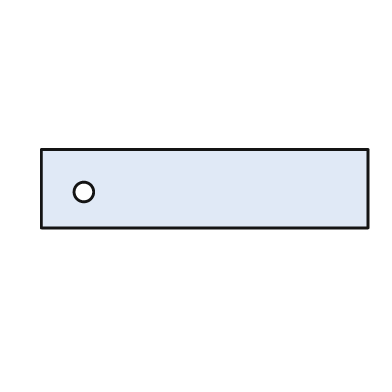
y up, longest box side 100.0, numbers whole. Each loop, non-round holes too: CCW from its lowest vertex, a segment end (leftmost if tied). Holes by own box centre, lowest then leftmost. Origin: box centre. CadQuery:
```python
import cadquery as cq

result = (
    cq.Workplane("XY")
    .moveTo(-50.0, -12.0)
    .lineTo(50.0, -12.0)
    .lineTo(50.0, 12.0)
    .lineTo(-50.0, 12.0)
    .close()
    .moveTo(-37.0, -1.0)
    .circle(3.0)
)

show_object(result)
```